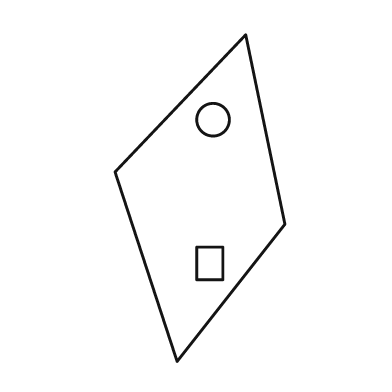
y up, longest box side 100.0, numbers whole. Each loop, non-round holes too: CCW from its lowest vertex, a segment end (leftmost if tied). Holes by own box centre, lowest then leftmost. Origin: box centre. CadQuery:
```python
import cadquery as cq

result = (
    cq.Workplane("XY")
    .moveTo(-7.0, -50.0)
    .lineTo(26.0, -8.0)
    .lineTo(14.0, 50.0)
    .lineTo(-26.0, 8.0)
    .close()
    .moveTo(-1.0, -25.0)
    .lineTo(7.0, -25.0)
    .lineTo(7.0, -15.0)
    .lineTo(-1.0, -15.0)
    .close()
    .moveTo(4.0, 24.0)
    .circle(5.0)
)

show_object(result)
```